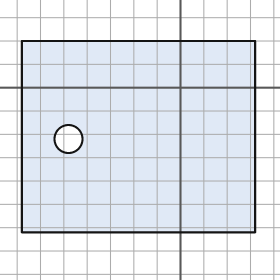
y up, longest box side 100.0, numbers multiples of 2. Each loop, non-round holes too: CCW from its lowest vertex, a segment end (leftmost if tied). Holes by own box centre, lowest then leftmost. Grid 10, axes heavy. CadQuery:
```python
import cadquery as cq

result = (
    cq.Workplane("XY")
    .moveTo(-68.0, -62.0)
    .lineTo(32.0, -62.0)
    .lineTo(32.0, 20.0)
    .lineTo(-68.0, 20.0)
    .close()
    .moveTo(-48.0, -22.0)
    .circle(6.0)
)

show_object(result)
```